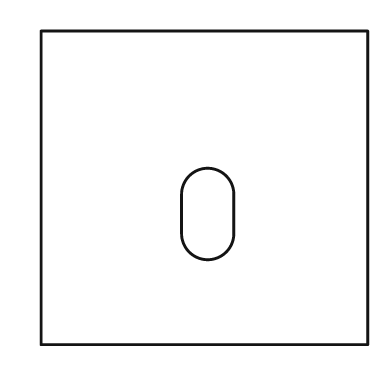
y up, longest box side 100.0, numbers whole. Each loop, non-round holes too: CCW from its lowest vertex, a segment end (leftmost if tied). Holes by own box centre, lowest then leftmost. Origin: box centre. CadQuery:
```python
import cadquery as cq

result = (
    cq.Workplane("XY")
    .moveTo(-50.0, -48.0)
    .lineTo(50.0, -48.0)
    .lineTo(50.0, 48.0)
    .lineTo(-50.0, 48.0)
    .close()
    .moveTo(-7.0, -14.0)
    .threePointArc((1.0, -22.0), (9.0, -14.0))
    .lineTo(9.0, -2.0)
    .threePointArc((1.0, 6.0), (-7.0, -2.0))
    .close()
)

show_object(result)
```